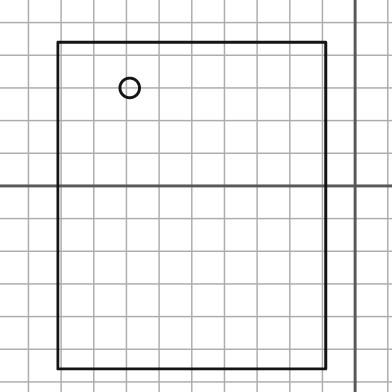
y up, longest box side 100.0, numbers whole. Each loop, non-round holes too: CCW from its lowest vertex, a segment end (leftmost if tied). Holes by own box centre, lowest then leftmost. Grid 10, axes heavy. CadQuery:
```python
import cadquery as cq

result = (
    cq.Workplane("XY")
    .moveTo(-91.0, -56.0)
    .lineTo(-9.0, -56.0)
    .lineTo(-9.0, 44.0)
    .lineTo(-91.0, 44.0)
    .close()
    .moveTo(-69.0, 30.0)
    .circle(3.0)
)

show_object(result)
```